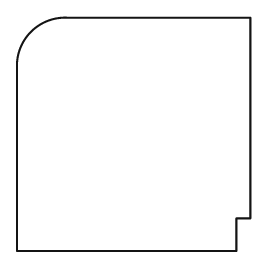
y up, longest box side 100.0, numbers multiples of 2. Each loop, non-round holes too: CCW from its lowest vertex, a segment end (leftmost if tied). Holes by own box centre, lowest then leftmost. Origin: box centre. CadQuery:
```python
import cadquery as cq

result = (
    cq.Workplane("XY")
    .moveTo(-50.0, -50.0)
    .lineTo(44.0, -50.0)
    .lineTo(44.0, -36.0)
    .lineTo(50.0, -36.0)
    .lineTo(50.0, 50.0)
    .lineTo(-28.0, 50.0)
    .threePointArc((-44.0, 44.0), (-50.0, 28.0))
    .close()
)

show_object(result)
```